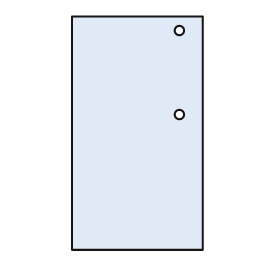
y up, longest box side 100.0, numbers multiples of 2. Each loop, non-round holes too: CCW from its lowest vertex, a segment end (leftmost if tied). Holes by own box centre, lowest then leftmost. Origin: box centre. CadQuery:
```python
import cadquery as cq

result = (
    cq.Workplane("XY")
    .moveTo(-28.0, -50.0)
    .lineTo(28.0, -50.0)
    .lineTo(28.0, 50.0)
    .lineTo(-28.0, 50.0)
    .close()
    .moveTo(18.0, 8.0)
    .circle(2.0)
    .moveTo(18.0, 44.0)
    .circle(2.0)
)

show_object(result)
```